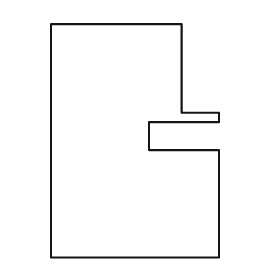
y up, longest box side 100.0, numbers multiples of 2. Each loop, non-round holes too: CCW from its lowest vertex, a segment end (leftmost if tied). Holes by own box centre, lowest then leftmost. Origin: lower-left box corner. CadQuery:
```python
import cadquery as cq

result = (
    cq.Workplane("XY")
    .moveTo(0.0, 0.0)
    .lineTo(72.0, 0.0)
    .lineTo(72.0, 46.0)
    .lineTo(42.0, 46.0)
    .lineTo(42.0, 58.0)
    .lineTo(72.0, 58.0)
    .lineTo(72.0, 62.0)
    .lineTo(56.0, 62.0)
    .lineTo(56.0, 100.0)
    .lineTo(0.0, 100.0)
    .close()
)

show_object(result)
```